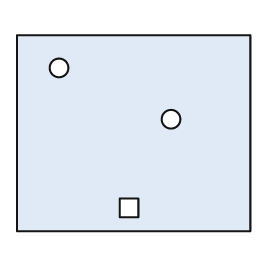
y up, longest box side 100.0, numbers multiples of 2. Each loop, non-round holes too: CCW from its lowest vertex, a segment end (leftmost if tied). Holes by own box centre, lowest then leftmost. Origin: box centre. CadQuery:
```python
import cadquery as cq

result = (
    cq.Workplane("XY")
    .moveTo(-50.0, -42.0)
    .lineTo(50.0, -42.0)
    .lineTo(50.0, 42.0)
    .lineTo(-50.0, 42.0)
    .close()
    .moveTo(-6.0, -36.0)
    .lineTo(2.0, -36.0)
    .lineTo(2.0, -28.0)
    .lineTo(-6.0, -28.0)
    .close()
    .moveTo(16.0, 6.0)
    .circle(4.0)
    .moveTo(-32.0, 28.0)
    .circle(4.0)
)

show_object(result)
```